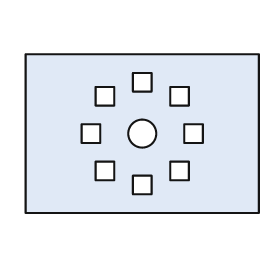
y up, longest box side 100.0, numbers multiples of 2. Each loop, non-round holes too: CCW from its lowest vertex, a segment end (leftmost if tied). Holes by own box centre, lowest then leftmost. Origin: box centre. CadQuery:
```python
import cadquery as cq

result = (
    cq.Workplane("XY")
    .moveTo(-50.0, -34.0)
    .lineTo(50.0, -34.0)
    .lineTo(50.0, 34.0)
    .lineTo(-50.0, 34.0)
    .close()
    .moveTo(-4.0, -26.0)
    .lineTo(4.0, -26.0)
    .lineTo(4.0, -18.0)
    .lineTo(-4.0, -18.0)
    .close()
    .moveTo(-20.0, -20.0)
    .lineTo(-12.0, -20.0)
    .lineTo(-12.0, -12.0)
    .lineTo(-20.0, -12.0)
    .close()
    .moveTo(12.0, -20.0)
    .lineTo(20.0, -20.0)
    .lineTo(20.0, -12.0)
    .lineTo(12.0, -12.0)
    .close()
    .moveTo(-26.0, -4.0)
    .lineTo(-18.0, -4.0)
    .lineTo(-18.0, 4.0)
    .lineTo(-26.0, 4.0)
    .close()
    .moveTo(0.0, 0.0)
    .circle(6.0)
    .moveTo(18.0, -4.0)
    .lineTo(26.0, -4.0)
    .lineTo(26.0, 4.0)
    .lineTo(18.0, 4.0)
    .close()
    .moveTo(-20.0, 12.0)
    .lineTo(-12.0, 12.0)
    .lineTo(-12.0, 20.0)
    .lineTo(-20.0, 20.0)
    .close()
    .moveTo(12.0, 12.0)
    .lineTo(20.0, 12.0)
    .lineTo(20.0, 20.0)
    .lineTo(12.0, 20.0)
    .close()
    .moveTo(-4.0, 18.0)
    .lineTo(4.0, 18.0)
    .lineTo(4.0, 26.0)
    .lineTo(-4.0, 26.0)
    .close()
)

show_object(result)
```